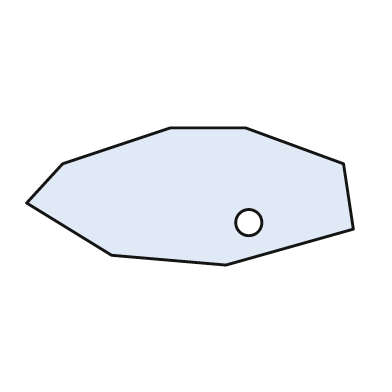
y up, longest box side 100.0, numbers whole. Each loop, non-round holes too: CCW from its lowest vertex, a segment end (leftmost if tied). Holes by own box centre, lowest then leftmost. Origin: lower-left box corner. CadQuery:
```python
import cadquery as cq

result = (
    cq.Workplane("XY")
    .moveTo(61.0, 0.0)
    .lineTo(100.0, 11.0)
    .lineTo(97.0, 31.0)
    .lineTo(67.0, 42.0)
    .lineTo(44.0, 42.0)
    .lineTo(11.0, 31.0)
    .lineTo(0.0, 19.0)
    .lineTo(26.0, 3.0)
    .close()
    .moveTo(68.0, 13.0)
    .circle(4.0)
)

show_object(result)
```